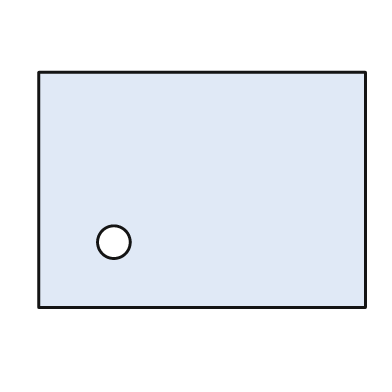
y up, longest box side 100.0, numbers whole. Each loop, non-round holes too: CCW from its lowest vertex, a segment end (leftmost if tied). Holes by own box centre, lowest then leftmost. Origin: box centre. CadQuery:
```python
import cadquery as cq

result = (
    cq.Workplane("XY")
    .moveTo(-50.0, -36.0)
    .lineTo(50.0, -36.0)
    .lineTo(50.0, 36.0)
    .lineTo(-50.0, 36.0)
    .close()
    .moveTo(-27.0, -16.0)
    .circle(5.0)
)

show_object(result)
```